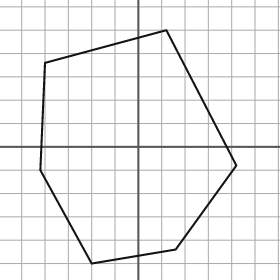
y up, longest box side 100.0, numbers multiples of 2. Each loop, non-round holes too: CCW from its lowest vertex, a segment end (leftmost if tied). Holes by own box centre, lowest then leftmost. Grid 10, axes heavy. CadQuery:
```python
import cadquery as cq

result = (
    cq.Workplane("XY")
    .moveTo(-20.0, -50.0)
    .lineTo(16.0, -44.0)
    .lineTo(42.0, -8.0)
    .lineTo(12.0, 50.0)
    .lineTo(-40.0, 36.0)
    .lineTo(-42.0, -10.0)
    .close()
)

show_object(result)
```